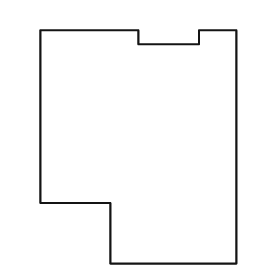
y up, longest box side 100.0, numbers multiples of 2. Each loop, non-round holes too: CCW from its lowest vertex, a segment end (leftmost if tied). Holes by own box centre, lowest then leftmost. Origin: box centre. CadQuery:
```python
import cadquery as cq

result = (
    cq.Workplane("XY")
    .moveTo(-12.0, -50.0)
    .lineTo(42.0, -50.0)
    .lineTo(42.0, 50.0)
    .lineTo(26.0, 50.0)
    .lineTo(26.0, 44.0)
    .lineTo(0.0, 44.0)
    .lineTo(0.0, 50.0)
    .lineTo(-42.0, 50.0)
    .lineTo(-42.0, -24.0)
    .lineTo(-12.0, -24.0)
    .close()
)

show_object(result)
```